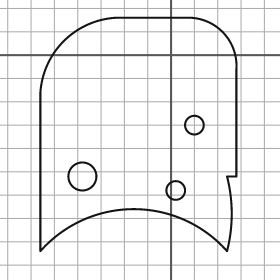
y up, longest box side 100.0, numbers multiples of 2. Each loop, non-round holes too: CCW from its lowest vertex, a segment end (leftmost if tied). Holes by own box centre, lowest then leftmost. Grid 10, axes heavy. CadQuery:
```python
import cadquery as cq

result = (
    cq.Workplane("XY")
    .moveTo(-56.0, -84.0)
    .threePointArc((-16.0, -66.0), (24.0, -84.0))
    .threePointArc((26.0, -68.0), (24.0, -52.0))
    .lineTo(28.0, -52.0)
    .lineTo(28.0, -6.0)
    .threePointArc((22.0, 10.0), (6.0, 16.0))
    .lineTo(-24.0, 16.0)
    .threePointArc((-46.0, 6.0), (-56.0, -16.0))
    .close()
    .moveTo(2.0, -58.0)
    .circle(4.0)
    .moveTo(-38.0, -52.0)
    .circle(6.0)
    .moveTo(10.0, -30.0)
    .circle(4.0)
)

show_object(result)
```